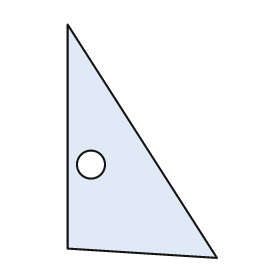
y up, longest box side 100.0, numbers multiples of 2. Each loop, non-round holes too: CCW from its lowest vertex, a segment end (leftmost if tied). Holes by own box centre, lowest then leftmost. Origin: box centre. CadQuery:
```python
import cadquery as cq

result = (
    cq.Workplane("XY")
    .moveTo(32.0, -50.0)
    .lineTo(-32.0, 50.0)
    .lineTo(-32.0, -46.0)
    .close()
    .moveTo(-22.0, -10.0)
    .circle(6.0)
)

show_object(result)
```